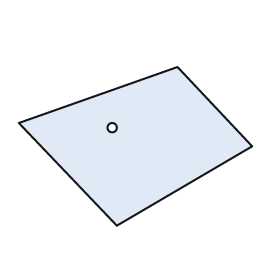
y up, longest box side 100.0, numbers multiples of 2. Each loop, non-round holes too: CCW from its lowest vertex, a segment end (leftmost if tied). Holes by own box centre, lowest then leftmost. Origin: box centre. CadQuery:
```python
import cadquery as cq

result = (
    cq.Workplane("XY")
    .moveTo(-8.0, -34.0)
    .lineTo(50.0, 0.0)
    .lineTo(18.0, 34.0)
    .lineTo(-50.0, 10.0)
    .close()
    .moveTo(-10.0, 8.0)
    .circle(2.0)
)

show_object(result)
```